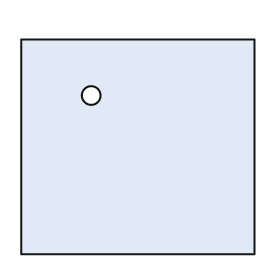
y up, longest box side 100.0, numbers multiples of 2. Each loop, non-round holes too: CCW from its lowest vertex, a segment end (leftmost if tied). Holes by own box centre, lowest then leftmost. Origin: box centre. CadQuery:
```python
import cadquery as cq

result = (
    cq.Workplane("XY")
    .moveTo(-50.0, -46.0)
    .lineTo(50.0, -46.0)
    .lineTo(50.0, 46.0)
    .lineTo(-50.0, 46.0)
    .close()
    .moveTo(-20.0, 22.0)
    .circle(4.0)
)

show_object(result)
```